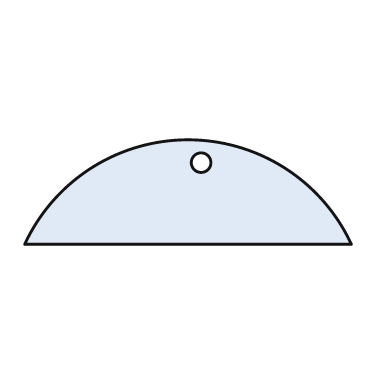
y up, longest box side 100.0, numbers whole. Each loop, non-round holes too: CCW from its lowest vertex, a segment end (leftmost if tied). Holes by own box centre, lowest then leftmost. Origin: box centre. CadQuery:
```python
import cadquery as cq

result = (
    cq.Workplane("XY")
    .moveTo(-50.0, -16.0)
    .lineTo(50.0, -16.0)
    .threePointArc((0.0, 16.0), (-50.0, -16.0))
    .close()
    .moveTo(4.0, 9.0)
    .circle(3.0)
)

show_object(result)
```